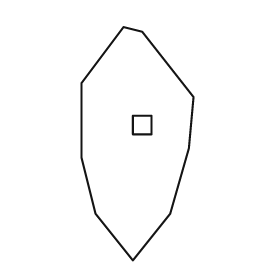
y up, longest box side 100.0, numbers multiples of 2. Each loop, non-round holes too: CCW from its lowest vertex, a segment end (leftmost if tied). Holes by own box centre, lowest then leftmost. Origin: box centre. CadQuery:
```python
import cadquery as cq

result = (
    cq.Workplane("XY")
    .moveTo(-2.0, -50.0)
    .lineTo(14.0, -30.0)
    .lineTo(22.0, -2.0)
    .lineTo(24.0, 20.0)
    .lineTo(2.0, 48.0)
    .lineTo(-6.0, 50.0)
    .lineTo(-24.0, 26.0)
    .lineTo(-24.0, -6.0)
    .lineTo(-18.0, -30.0)
    .close()
    .moveTo(-2.0, 4.0)
    .lineTo(6.0, 4.0)
    .lineTo(6.0, 12.0)
    .lineTo(-2.0, 12.0)
    .close()
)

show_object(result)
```